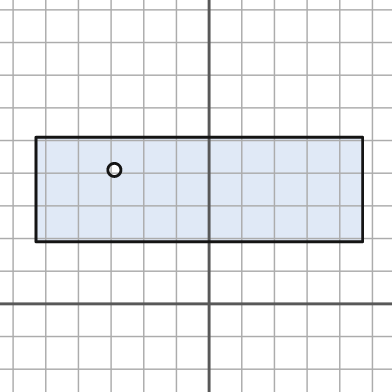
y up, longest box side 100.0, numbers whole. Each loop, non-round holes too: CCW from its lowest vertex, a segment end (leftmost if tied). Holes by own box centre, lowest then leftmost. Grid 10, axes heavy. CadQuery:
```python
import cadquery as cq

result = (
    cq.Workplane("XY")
    .moveTo(-53.0, 19.0)
    .lineTo(47.0, 19.0)
    .lineTo(47.0, 51.0)
    .lineTo(-53.0, 51.0)
    .close()
    .moveTo(-29.0, 41.0)
    .circle(2.0)
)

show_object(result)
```